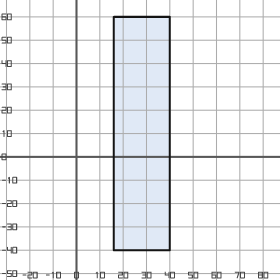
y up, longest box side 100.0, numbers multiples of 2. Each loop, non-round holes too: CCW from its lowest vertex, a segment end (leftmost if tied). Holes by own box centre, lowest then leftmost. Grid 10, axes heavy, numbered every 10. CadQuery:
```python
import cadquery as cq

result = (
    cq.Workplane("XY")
    .moveTo(16.0, -40.0)
    .lineTo(40.0, -40.0)
    .lineTo(40.0, 60.0)
    .lineTo(16.0, 60.0)
    .close()
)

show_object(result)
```